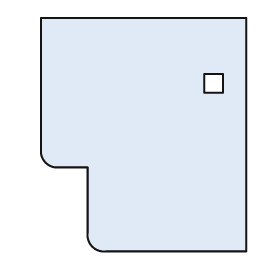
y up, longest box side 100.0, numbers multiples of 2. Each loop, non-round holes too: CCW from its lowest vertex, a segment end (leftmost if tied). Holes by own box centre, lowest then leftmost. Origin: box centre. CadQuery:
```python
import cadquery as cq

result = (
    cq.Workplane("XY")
    .moveTo(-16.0, -50.0)
    .lineTo(44.0, -50.0)
    .lineTo(44.0, 50.0)
    .lineTo(-44.0, 50.0)
    .lineTo(-44.0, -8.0)
    .threePointArc((-42.0, -12.0), (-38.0, -14.0))
    .lineTo(-24.0, -14.0)
    .lineTo(-24.0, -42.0)
    .threePointArc((-22.0, -48.0), (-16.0, -50.0))
    .close()
    .moveTo(26.0, 18.0)
    .lineTo(34.0, 18.0)
    .lineTo(34.0, 26.0)
    .lineTo(26.0, 26.0)
    .close()
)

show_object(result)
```